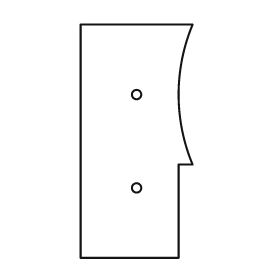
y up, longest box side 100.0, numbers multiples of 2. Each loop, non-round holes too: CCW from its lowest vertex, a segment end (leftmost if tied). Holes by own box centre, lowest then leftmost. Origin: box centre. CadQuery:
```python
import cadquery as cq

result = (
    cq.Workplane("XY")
    .moveTo(-24.0, -50.0)
    .lineTo(18.0, -50.0)
    .lineTo(18.0, -10.0)
    .lineTo(24.0, -10.0)
    .threePointArc((18.0, 20.0), (24.0, 50.0))
    .lineTo(-24.0, 50.0)
    .close()
    .moveTo(0.0, -20.0)
    .circle(2.0)
    .moveTo(0.0, 20.0)
    .circle(2.0)
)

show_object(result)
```